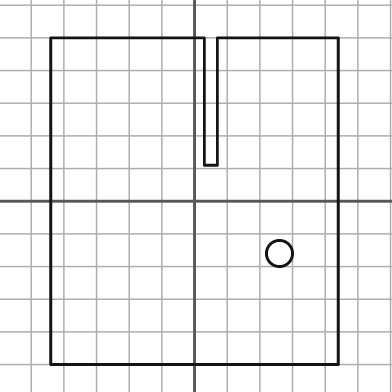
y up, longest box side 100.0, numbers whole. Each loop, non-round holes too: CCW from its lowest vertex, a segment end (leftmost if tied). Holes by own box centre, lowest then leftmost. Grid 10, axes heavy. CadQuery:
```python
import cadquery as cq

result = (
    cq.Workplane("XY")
    .moveTo(-44.0, -50.0)
    .lineTo(44.0, -50.0)
    .lineTo(44.0, 50.0)
    .lineTo(7.0, 50.0)
    .lineTo(7.0, 11.0)
    .lineTo(3.0, 11.0)
    .lineTo(3.0, 50.0)
    .lineTo(-44.0, 50.0)
    .close()
    .moveTo(26.0, -16.0)
    .circle(4.0)
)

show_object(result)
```